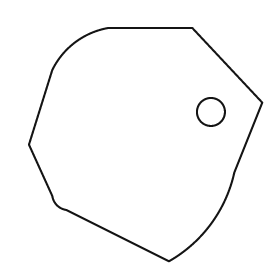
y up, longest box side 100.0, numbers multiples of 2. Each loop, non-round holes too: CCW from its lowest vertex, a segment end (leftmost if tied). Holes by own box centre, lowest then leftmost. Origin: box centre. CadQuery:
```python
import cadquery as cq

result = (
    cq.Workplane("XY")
    .moveTo(10.0, -50.0)
    .threePointArc((28.0, -34.0), (38.0, -12.0))
    .lineTo(50.0, 18.0)
    .lineTo(20.0, 50.0)
    .lineTo(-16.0, 50.0)
    .threePointArc((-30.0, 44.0), (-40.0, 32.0))
    .lineTo(-50.0, 0.0)
    .lineTo(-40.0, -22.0)
    .threePointArc((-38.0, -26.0), (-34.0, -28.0))
    .close()
    .moveTo(28.0, 14.0)
    .circle(6.0)
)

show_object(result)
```